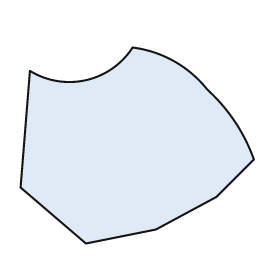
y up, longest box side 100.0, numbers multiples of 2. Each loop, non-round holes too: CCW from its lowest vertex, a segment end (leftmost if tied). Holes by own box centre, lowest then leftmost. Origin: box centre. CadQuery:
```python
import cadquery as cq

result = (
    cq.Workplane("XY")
    .moveTo(-22.0, -42.0)
    .lineTo(8.0, -36.0)
    .lineTo(34.0, -22.0)
    .lineTo(50.0, -6.0)
    .threePointArc((42.0, 10.0), (30.0, 24.0))
    .threePointArc((16.0, 36.0), (-2.0, 42.0))
    .threePointArc((-22.0, 28.0), (-46.0, 32.0))
    .lineTo(-50.0, -18.0)
    .close()
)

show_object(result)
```